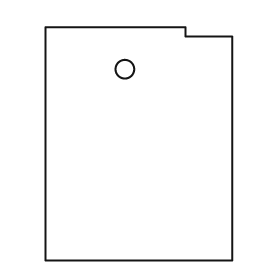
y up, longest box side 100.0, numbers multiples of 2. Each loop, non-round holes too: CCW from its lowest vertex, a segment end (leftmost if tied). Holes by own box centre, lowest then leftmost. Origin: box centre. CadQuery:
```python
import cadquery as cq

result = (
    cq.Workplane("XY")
    .moveTo(-40.0, -50.0)
    .lineTo(40.0, -50.0)
    .lineTo(40.0, 46.0)
    .lineTo(20.0, 46.0)
    .lineTo(20.0, 50.0)
    .lineTo(-40.0, 50.0)
    .close()
    .moveTo(-6.0, 32.0)
    .circle(4.0)
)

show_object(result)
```